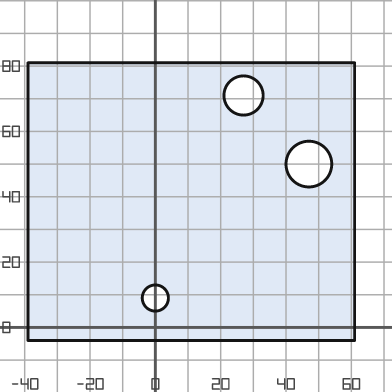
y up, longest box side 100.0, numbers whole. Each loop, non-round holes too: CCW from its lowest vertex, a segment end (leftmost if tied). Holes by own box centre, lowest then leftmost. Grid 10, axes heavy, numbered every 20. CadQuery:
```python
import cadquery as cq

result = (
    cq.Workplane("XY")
    .moveTo(-39.0, -4.0)
    .lineTo(61.0, -4.0)
    .lineTo(61.0, 81.0)
    .lineTo(-39.0, 81.0)
    .close()
    .moveTo(0.0, 9.0)
    .circle(4.0)
    .moveTo(47.0, 50.0)
    .circle(7.0)
    .moveTo(27.0, 71.0)
    .circle(6.0)
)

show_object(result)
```